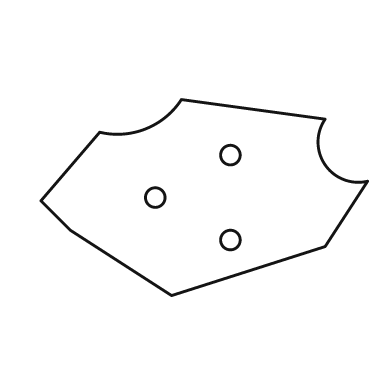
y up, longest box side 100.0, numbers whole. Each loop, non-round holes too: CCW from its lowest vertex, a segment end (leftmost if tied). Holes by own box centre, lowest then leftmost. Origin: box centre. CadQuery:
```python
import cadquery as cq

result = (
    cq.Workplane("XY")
    .moveTo(-10.0, -30.0)
    .lineTo(37.0, -15.0)
    .lineTo(50.0, 5.0)
    .threePointArc((37.0, 10.0), (37.0, 24.0))
    .lineTo(-7.0, 30.0)
    .threePointArc((-18.0, 21.0), (-32.0, 20.0))
    .lineTo(-50.0, -1.0)
    .lineTo(-41.0, -10.0)
    .close()
    .moveTo(8.0, -13.0)
    .circle(3.0)
    .moveTo(-15.0, 0.0)
    .circle(3.0)
    .moveTo(8.0, 13.0)
    .circle(3.0)
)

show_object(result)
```